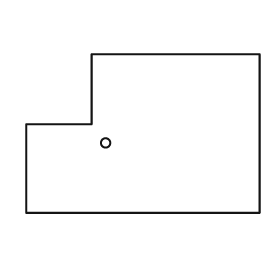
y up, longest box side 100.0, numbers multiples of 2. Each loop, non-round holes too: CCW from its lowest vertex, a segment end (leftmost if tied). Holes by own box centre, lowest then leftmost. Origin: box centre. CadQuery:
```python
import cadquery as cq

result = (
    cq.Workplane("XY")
    .moveTo(-50.0, -34.0)
    .lineTo(50.0, -34.0)
    .lineTo(50.0, 34.0)
    .lineTo(-22.0, 34.0)
    .lineTo(-22.0, 4.0)
    .lineTo(-50.0, 4.0)
    .close()
    .moveTo(-16.0, -4.0)
    .circle(2.0)
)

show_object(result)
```